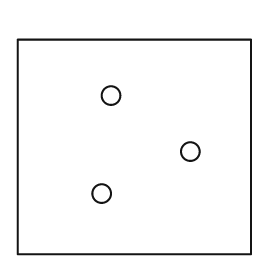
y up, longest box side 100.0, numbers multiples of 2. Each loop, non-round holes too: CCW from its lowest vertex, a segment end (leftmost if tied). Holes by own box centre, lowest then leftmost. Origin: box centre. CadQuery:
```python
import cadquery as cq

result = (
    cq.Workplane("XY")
    .moveTo(-50.0, -46.0)
    .lineTo(50.0, -46.0)
    .lineTo(50.0, 46.0)
    .lineTo(-50.0, 46.0)
    .close()
    .moveTo(-14.0, -20.0)
    .circle(4.0)
    .moveTo(24.0, -2.0)
    .circle(4.0)
    .moveTo(-10.0, 22.0)
    .circle(4.0)
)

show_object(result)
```